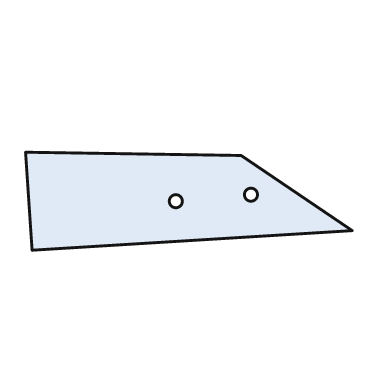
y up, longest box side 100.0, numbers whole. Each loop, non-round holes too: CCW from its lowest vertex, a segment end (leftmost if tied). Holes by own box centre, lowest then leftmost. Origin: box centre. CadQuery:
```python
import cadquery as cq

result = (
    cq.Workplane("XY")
    .moveTo(-48.0, -15.0)
    .lineTo(50.0, -9.0)
    .lineTo(16.0, 14.0)
    .lineTo(-50.0, 15.0)
    .close()
    .moveTo(-4.0, 0.0)
    .circle(2.0)
    .moveTo(19.0, 2.0)
    .circle(2.0)
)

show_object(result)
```